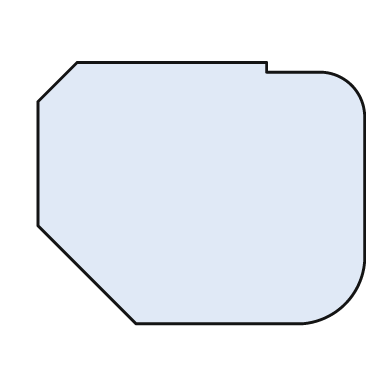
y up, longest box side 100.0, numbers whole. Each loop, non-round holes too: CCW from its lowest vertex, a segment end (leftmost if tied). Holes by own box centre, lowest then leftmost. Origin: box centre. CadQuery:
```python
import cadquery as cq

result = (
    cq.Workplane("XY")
    .moveTo(-20.0, -40.0)
    .lineTo(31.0, -40.0)
    .threePointArc((44.0, -34.0), (50.0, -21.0))
    .lineTo(50.0, 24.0)
    .threePointArc((46.0, 33.0), (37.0, 37.0))
    .lineTo(20.0, 37.0)
    .lineTo(20.0, 40.0)
    .lineTo(-38.0, 40.0)
    .lineTo(-50.0, 28.0)
    .lineTo(-50.0, -10.0)
    .close()
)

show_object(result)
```